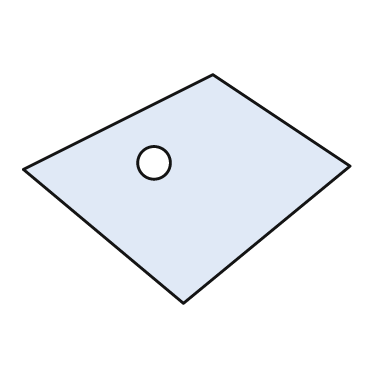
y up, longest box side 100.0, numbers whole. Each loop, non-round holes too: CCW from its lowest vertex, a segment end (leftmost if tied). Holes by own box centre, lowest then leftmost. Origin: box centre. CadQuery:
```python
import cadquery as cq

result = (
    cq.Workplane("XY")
    .moveTo(-1.0, -35.0)
    .lineTo(50.0, 7.0)
    .lineTo(8.0, 35.0)
    .lineTo(-50.0, 6.0)
    .close()
    .moveTo(-10.0, 8.0)
    .circle(5.0)
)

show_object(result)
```